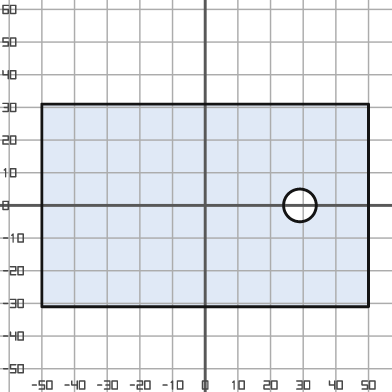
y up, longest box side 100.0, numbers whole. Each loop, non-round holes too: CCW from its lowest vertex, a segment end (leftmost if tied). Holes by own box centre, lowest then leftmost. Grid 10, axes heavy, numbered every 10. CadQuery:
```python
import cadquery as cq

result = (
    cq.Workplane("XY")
    .moveTo(-50.0, -31.0)
    .lineTo(50.0, -31.0)
    .lineTo(50.0, 31.0)
    .lineTo(-50.0, 31.0)
    .close()
    .moveTo(29.0, 0.0)
    .circle(5.0)
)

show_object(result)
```